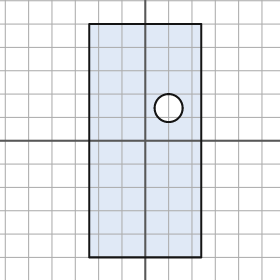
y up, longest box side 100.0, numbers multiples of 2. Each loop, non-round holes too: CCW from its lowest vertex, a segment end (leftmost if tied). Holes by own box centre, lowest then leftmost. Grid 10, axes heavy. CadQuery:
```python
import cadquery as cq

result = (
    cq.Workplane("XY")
    .moveTo(-24.0, -50.0)
    .lineTo(24.0, -50.0)
    .lineTo(24.0, 50.0)
    .lineTo(-24.0, 50.0)
    .close()
    .moveTo(10.0, 14.0)
    .circle(6.0)
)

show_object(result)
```